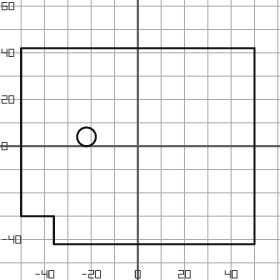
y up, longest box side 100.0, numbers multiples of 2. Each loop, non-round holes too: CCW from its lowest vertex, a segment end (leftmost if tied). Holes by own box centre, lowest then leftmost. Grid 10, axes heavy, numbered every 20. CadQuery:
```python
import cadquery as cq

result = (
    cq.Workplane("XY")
    .moveTo(-36.0, -42.0)
    .lineTo(50.0, -42.0)
    .lineTo(50.0, 42.0)
    .lineTo(-50.0, 42.0)
    .lineTo(-50.0, -30.0)
    .lineTo(-36.0, -30.0)
    .close()
    .moveTo(-22.0, 4.0)
    .circle(4.0)
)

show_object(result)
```